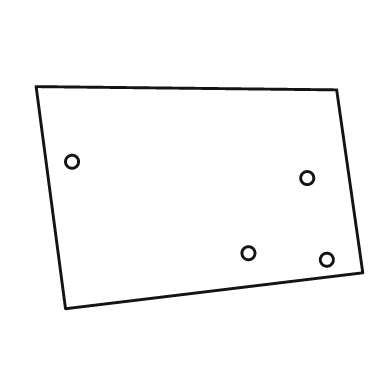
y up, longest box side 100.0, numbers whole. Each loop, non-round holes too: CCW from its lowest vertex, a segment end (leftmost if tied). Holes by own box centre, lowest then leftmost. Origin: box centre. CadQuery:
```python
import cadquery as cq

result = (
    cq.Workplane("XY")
    .moveTo(-41.0, -34.0)
    .lineTo(50.0, -23.0)
    .lineTo(42.0, 33.0)
    .lineTo(-50.0, 34.0)
    .close()
    .moveTo(39.0, -19.0)
    .circle(2.0)
    .moveTo(15.0, -17.0)
    .circle(2.0)
    .moveTo(33.0, 6.0)
    .circle(2.0)
    .moveTo(-39.0, 11.0)
    .circle(2.0)
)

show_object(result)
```